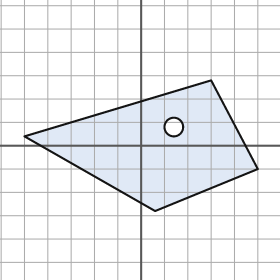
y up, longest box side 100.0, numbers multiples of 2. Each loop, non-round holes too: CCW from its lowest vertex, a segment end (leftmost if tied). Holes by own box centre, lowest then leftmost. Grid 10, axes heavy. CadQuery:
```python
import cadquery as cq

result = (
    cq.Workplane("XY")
    .moveTo(6.0, -28.0)
    .lineTo(50.0, -10.0)
    .lineTo(30.0, 28.0)
    .lineTo(-50.0, 4.0)
    .close()
    .moveTo(14.0, 8.0)
    .circle(4.0)
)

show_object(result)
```